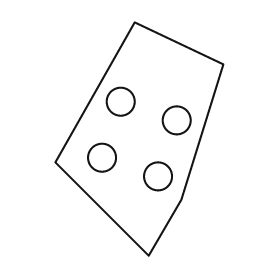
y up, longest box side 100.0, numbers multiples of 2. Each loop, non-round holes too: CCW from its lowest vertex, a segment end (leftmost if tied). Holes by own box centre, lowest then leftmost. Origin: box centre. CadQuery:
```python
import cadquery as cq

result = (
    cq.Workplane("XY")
    .moveTo(4.0, -50.0)
    .lineTo(18.0, -26.0)
    .lineTo(36.0, 32.0)
    .lineTo(-2.0, 50.0)
    .lineTo(-36.0, -10.0)
    .close()
    .moveTo(8.0, -16.0)
    .circle(6.0)
    .moveTo(-16.0, -8.0)
    .circle(6.0)
    .moveTo(16.0, 8.0)
    .circle(6.0)
    .moveTo(-8.0, 16.0)
    .circle(6.0)
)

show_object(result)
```